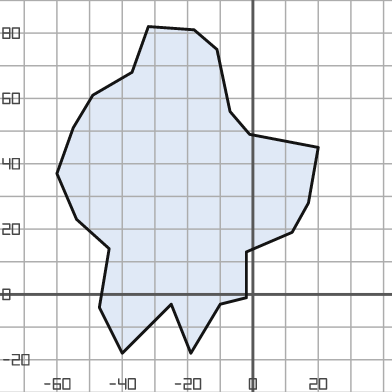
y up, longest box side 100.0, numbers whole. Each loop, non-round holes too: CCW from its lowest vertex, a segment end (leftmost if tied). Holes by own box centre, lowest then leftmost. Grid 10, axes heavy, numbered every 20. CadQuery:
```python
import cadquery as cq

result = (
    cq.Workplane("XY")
    .moveTo(-40.0, -18.0)
    .lineTo(-25.0, -3.0)
    .lineTo(-19.0, -18.0)
    .lineTo(-10.0, -3.0)
    .lineTo(-2.0, -1.0)
    .lineTo(-2.0, 13.0)
    .lineTo(12.0, 19.0)
    .lineTo(17.0, 28.0)
    .lineTo(20.0, 45.0)
    .lineTo(-1.0, 49.0)
    .lineTo(-7.0, 56.0)
    .lineTo(-11.0, 75.0)
    .lineTo(-18.0, 81.0)
    .lineTo(-32.0, 82.0)
    .lineTo(-37.0, 68.0)
    .lineTo(-49.0, 61.0)
    .lineTo(-55.0, 51.0)
    .lineTo(-60.0, 37.0)
    .lineTo(-54.0, 23.0)
    .lineTo(-44.0, 14.0)
    .lineTo(-47.0, -4.0)
    .close()
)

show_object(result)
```